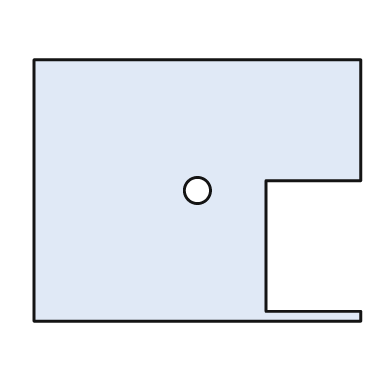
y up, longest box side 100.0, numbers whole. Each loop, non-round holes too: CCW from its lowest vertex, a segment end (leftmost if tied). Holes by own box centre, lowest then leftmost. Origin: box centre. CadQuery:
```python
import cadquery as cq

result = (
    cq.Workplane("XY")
    .moveTo(-50.0, -40.0)
    .lineTo(50.0, -40.0)
    .lineTo(50.0, -37.0)
    .lineTo(21.0, -37.0)
    .lineTo(21.0, 3.0)
    .lineTo(50.0, 3.0)
    .lineTo(50.0, 40.0)
    .lineTo(-50.0, 40.0)
    .close()
    .moveTo(0.0, 0.0)
    .circle(4.0)
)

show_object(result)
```